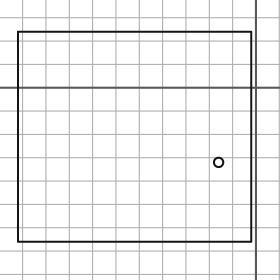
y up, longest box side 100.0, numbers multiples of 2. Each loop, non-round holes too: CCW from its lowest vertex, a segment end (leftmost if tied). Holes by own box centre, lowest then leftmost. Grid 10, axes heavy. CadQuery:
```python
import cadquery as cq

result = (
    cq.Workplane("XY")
    .moveTo(-102.0, -66.0)
    .lineTo(-2.0, -66.0)
    .lineTo(-2.0, 24.0)
    .lineTo(-102.0, 24.0)
    .close()
    .moveTo(-16.0, -32.0)
    .circle(2.0)
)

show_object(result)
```